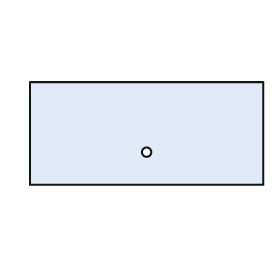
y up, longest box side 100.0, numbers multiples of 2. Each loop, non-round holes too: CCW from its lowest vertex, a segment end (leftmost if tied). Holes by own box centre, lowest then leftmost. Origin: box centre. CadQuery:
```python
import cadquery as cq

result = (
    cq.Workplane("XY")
    .moveTo(-50.0, -22.0)
    .lineTo(50.0, -22.0)
    .lineTo(50.0, 22.0)
    .lineTo(-50.0, 22.0)
    .close()
    .moveTo(0.0, -8.0)
    .circle(2.0)
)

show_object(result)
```